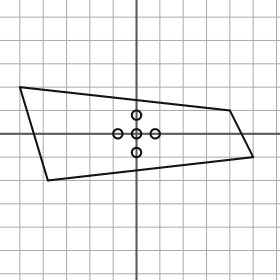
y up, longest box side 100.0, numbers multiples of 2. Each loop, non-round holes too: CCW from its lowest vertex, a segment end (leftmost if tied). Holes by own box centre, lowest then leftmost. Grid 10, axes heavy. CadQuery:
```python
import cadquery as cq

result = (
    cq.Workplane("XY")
    .moveTo(-38.0, -20.0)
    .lineTo(50.0, -10.0)
    .lineTo(40.0, 10.0)
    .lineTo(-50.0, 20.0)
    .close()
    .moveTo(0.0, -8.0)
    .circle(2.0)
    .moveTo(-8.0, 0.0)
    .circle(2.0)
    .moveTo(0.0, 0.0)
    .circle(2.0)
    .moveTo(8.0, 0.0)
    .circle(2.0)
    .moveTo(0.0, 8.0)
    .circle(2.0)
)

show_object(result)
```